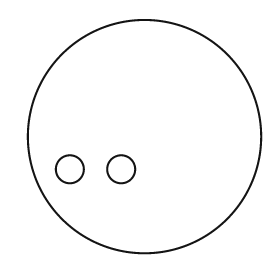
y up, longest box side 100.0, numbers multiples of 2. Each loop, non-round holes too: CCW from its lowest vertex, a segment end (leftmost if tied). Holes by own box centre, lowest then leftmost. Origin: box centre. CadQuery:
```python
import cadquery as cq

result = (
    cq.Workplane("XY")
    .moveTo(0.0, 0.0)
    .circle(50.0)
    .moveTo(-32.0, -14.0)
    .circle(6.0)
    .moveTo(-10.0, -14.0)
    .circle(6.0)
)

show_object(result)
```